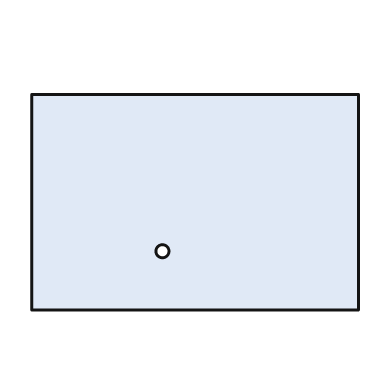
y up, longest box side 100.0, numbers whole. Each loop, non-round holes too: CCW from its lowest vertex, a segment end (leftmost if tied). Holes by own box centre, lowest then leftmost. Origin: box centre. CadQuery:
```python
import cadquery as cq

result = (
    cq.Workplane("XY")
    .moveTo(-50.0, -33.0)
    .lineTo(50.0, -33.0)
    .lineTo(50.0, 33.0)
    .lineTo(-50.0, 33.0)
    .close()
    .moveTo(-10.0, -15.0)
    .circle(2.0)
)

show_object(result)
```